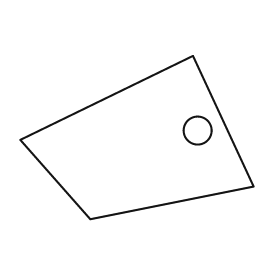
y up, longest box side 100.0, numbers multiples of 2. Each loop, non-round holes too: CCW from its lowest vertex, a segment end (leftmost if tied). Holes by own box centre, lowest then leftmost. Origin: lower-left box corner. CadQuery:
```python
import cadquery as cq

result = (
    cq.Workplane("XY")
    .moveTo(30.0, 0.0)
    .lineTo(100.0, 14.0)
    .lineTo(74.0, 70.0)
    .lineTo(0.0, 34.0)
    .close()
    .moveTo(76.0, 38.0)
    .circle(6.0)
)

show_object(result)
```